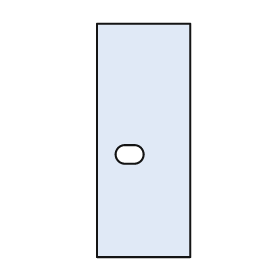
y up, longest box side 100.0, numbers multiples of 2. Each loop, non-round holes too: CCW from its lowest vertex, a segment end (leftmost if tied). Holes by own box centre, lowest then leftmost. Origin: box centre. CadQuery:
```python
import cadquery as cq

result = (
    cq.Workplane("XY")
    .moveTo(-20.0, -50.0)
    .lineTo(20.0, -50.0)
    .lineTo(20.0, 50.0)
    .lineTo(-20.0, 50.0)
    .close()
    .moveTo(-8.0, -10.0)
    .lineTo(-4.0, -10.0)
    .threePointArc((0.0, -6.0), (-4.0, -2.0))
    .lineTo(-8.0, -2.0)
    .threePointArc((-12.0, -6.0), (-8.0, -10.0))
    .close()
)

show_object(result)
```